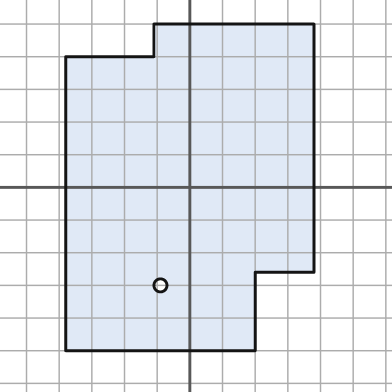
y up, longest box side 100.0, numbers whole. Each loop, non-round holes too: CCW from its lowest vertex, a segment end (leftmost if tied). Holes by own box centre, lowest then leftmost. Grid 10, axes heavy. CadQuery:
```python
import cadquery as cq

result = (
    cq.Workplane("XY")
    .moveTo(-38.0, -50.0)
    .lineTo(20.0, -50.0)
    .lineTo(20.0, -26.0)
    .lineTo(38.0, -26.0)
    .lineTo(38.0, 50.0)
    .lineTo(-11.0, 50.0)
    .lineTo(-11.0, 40.0)
    .lineTo(-38.0, 40.0)
    .close()
    .moveTo(-9.0, -30.0)
    .circle(2.0)
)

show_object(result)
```